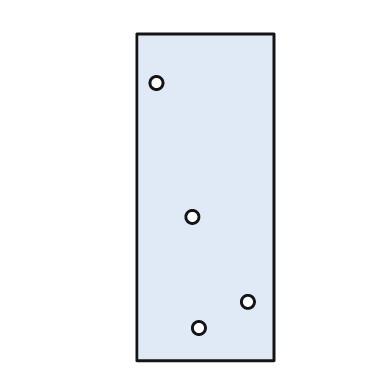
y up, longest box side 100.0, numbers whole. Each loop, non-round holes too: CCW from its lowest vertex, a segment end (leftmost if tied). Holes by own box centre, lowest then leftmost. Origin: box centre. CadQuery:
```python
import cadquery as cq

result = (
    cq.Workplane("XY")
    .moveTo(-21.0, -50.0)
    .lineTo(21.0, -50.0)
    .lineTo(21.0, 50.0)
    .lineTo(-21.0, 50.0)
    .close()
    .moveTo(-2.0, -40.0)
    .circle(2.0)
    .moveTo(13.0, -32.0)
    .circle(2.0)
    .moveTo(-4.0, -6.0)
    .circle(2.0)
    .moveTo(-15.0, 35.0)
    .circle(2.0)
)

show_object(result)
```